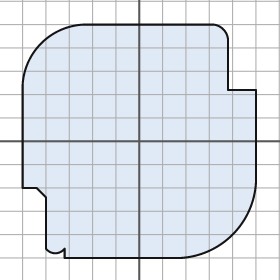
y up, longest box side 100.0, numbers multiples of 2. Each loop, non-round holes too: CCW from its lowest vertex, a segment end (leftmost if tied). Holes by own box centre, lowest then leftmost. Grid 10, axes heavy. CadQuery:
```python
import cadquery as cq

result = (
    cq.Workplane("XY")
    .moveTo(-32.0, -50.0)
    .lineTo(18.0, -50.0)
    .threePointArc((40.0, -40.0), (50.0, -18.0))
    .lineTo(50.0, 22.0)
    .lineTo(38.0, 22.0)
    .lineTo(38.0, 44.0)
    .threePointArc((36.0, 48.0), (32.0, 50.0))
    .lineTo(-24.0, 50.0)
    .threePointArc((-42.0, 42.0), (-50.0, 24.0))
    .lineTo(-50.0, -20.0)
    .lineTo(-44.0, -20.0)
    .lineTo(-40.0, -24.0)
    .lineTo(-40.0, -46.0)
    .threePointArc((-36.0, -48.0), (-32.0, -46.0))
    .close()
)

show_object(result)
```